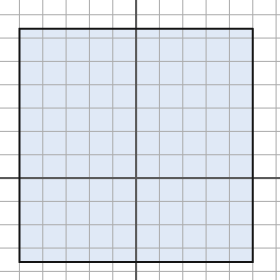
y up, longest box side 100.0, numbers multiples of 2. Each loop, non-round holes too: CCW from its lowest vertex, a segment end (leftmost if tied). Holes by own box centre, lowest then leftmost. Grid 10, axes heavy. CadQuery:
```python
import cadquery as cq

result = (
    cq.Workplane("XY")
    .moveTo(-50.0, -36.0)
    .lineTo(50.0, -36.0)
    .lineTo(50.0, 64.0)
    .lineTo(-50.0, 64.0)
    .close()
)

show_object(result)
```